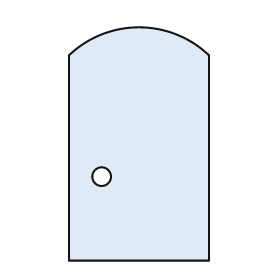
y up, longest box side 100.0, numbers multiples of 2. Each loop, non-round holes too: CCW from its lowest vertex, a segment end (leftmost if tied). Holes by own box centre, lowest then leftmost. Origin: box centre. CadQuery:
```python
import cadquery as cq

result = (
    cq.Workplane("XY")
    .moveTo(-30.0, -50.0)
    .lineTo(30.0, -50.0)
    .lineTo(30.0, 38.0)
    .threePointArc((0.0, 50.0), (-30.0, 38.0))
    .close()
    .moveTo(-16.0, -14.0)
    .circle(4.0)
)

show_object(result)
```